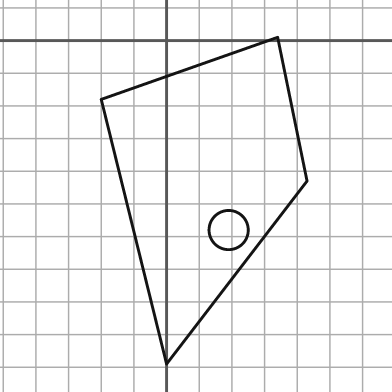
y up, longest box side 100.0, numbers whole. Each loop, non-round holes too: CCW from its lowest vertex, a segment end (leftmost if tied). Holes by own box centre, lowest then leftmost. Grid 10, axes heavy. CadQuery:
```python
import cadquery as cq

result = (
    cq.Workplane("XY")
    .moveTo(0.0, -99.0)
    .lineTo(43.0, -43.0)
    .lineTo(34.0, 1.0)
    .lineTo(-20.0, -18.0)
    .close()
    .moveTo(19.0, -58.0)
    .circle(6.0)
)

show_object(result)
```